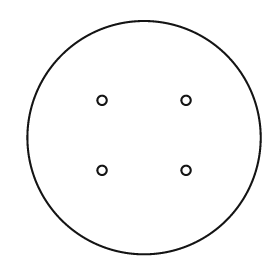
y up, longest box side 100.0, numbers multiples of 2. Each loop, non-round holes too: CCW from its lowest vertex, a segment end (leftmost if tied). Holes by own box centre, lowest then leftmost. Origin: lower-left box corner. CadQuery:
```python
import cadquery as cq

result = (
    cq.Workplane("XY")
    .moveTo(50.0, 50.0)
    .circle(50.0)
    .moveTo(32.0, 36.0)
    .circle(2.0)
    .moveTo(68.0, 36.0)
    .circle(2.0)
    .moveTo(32.0, 66.0)
    .circle(2.0)
    .moveTo(68.0, 66.0)
    .circle(2.0)
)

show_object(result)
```